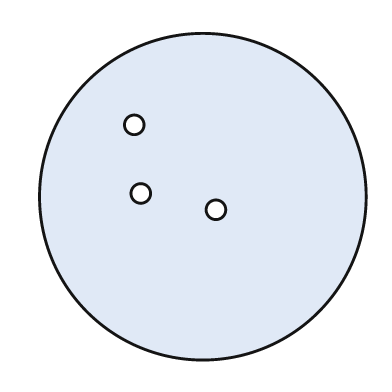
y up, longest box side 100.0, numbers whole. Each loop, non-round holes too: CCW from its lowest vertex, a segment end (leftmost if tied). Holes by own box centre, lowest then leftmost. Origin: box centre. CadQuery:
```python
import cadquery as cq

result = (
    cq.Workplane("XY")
    .moveTo(0.0, 0.0)
    .circle(50.0)
    .moveTo(4.0, -4.0)
    .circle(3.0)
    .moveTo(-19.0, 1.0)
    .circle(3.0)
    .moveTo(-21.0, 22.0)
    .circle(3.0)
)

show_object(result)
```